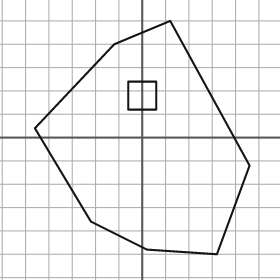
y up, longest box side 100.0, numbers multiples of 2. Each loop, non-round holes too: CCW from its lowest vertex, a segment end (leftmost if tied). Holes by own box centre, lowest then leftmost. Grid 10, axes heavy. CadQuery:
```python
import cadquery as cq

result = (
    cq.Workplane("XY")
    .moveTo(32.0, -50.0)
    .lineTo(46.0, -12.0)
    .lineTo(12.0, 50.0)
    .lineTo(-12.0, 40.0)
    .lineTo(-46.0, 4.0)
    .lineTo(-22.0, -36.0)
    .lineTo(2.0, -48.0)
    .close()
    .moveTo(-6.0, 12.0)
    .lineTo(6.0, 12.0)
    .lineTo(6.0, 24.0)
    .lineTo(-6.0, 24.0)
    .close()
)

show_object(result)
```